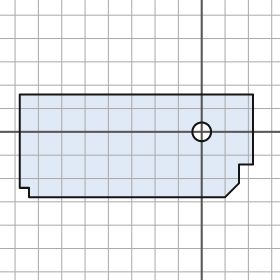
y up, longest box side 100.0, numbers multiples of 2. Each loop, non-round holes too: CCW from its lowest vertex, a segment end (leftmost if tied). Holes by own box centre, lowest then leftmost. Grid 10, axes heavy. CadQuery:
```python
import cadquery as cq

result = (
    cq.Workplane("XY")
    .moveTo(-74.0, -28.0)
    .lineTo(10.0, -28.0)
    .lineTo(16.0, -22.0)
    .lineTo(16.0, -14.0)
    .lineTo(22.0, -14.0)
    .lineTo(22.0, 16.0)
    .lineTo(-78.0, 16.0)
    .lineTo(-78.0, -24.0)
    .lineTo(-74.0, -24.0)
    .close()
    .moveTo(0.0, 0.0)
    .circle(4.0)
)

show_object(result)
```